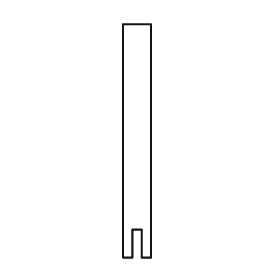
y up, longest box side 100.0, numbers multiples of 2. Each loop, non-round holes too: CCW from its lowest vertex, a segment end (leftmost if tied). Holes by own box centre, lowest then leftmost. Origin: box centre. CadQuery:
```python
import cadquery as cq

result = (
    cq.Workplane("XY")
    .moveTo(-6.0, -50.0)
    .lineTo(-2.0, -50.0)
    .lineTo(-2.0, -38.0)
    .lineTo(2.0, -38.0)
    .lineTo(2.0, -50.0)
    .lineTo(6.0, -50.0)
    .lineTo(6.0, 50.0)
    .lineTo(-6.0, 50.0)
    .close()
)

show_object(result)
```